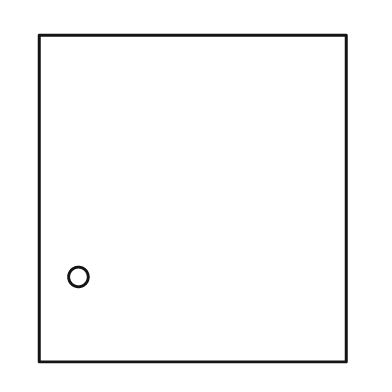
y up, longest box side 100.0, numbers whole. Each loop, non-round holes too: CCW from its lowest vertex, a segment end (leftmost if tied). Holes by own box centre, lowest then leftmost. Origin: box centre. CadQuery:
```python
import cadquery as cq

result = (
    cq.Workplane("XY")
    .moveTo(-47.0, -50.0)
    .lineTo(47.0, -50.0)
    .lineTo(47.0, 50.0)
    .lineTo(-47.0, 50.0)
    .close()
    .moveTo(-35.0, -24.0)
    .circle(3.0)
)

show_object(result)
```